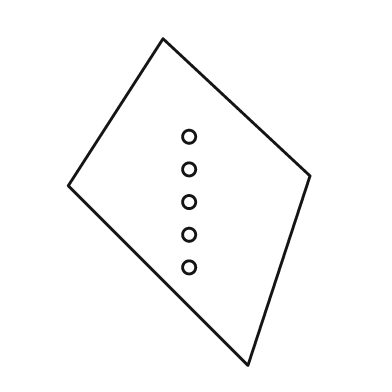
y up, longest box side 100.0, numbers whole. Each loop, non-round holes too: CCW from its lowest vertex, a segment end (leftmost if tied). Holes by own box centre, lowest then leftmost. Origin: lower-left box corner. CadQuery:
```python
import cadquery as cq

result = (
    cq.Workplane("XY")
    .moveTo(55.0, 0.0)
    .lineTo(74.0, 58.0)
    .lineTo(29.0, 100.0)
    .lineTo(0.0, 55.0)
    .close()
    .moveTo(37.0, 30.0)
    .circle(2.0)
    .moveTo(37.0, 40.0)
    .circle(2.0)
    .moveTo(37.0, 50.0)
    .circle(2.0)
    .moveTo(37.0, 60.0)
    .circle(2.0)
    .moveTo(37.0, 70.0)
    .circle(2.0)
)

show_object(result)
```